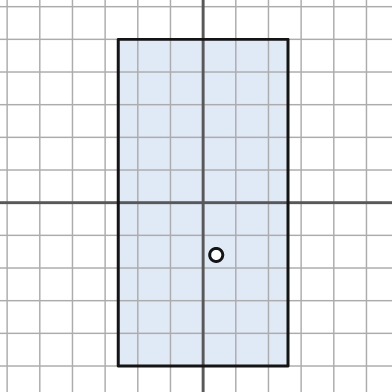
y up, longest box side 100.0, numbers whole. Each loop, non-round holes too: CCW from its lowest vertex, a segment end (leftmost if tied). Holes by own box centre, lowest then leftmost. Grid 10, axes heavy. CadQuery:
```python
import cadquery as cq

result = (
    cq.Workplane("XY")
    .moveTo(-26.0, -50.0)
    .lineTo(26.0, -50.0)
    .lineTo(26.0, 50.0)
    .lineTo(-26.0, 50.0)
    .close()
    .moveTo(4.0, -16.0)
    .circle(2.0)
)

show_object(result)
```